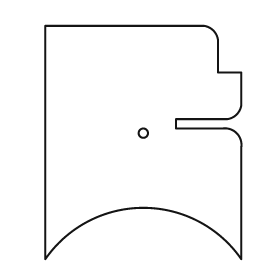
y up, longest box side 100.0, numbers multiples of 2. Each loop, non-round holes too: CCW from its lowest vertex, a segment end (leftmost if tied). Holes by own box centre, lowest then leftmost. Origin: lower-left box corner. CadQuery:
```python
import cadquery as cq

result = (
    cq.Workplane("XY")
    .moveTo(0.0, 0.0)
    .threePointArc((42.0, 22.0), (84.0, 0.0))
    .lineTo(84.0, 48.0)
    .threePointArc((82.0, 54.0), (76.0, 56.0))
    .lineTo(56.0, 56.0)
    .lineTo(56.0, 60.0)
    .lineTo(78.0, 60.0)
    .threePointArc((82.0, 62.0), (84.0, 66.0))
    .lineTo(84.0, 80.0)
    .lineTo(74.0, 80.0)
    .lineTo(74.0, 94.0)
    .threePointArc((72.0, 98.0), (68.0, 100.0))
    .lineTo(0.0, 100.0)
    .close()
    .moveTo(42.0, 54.0)
    .circle(2.0)
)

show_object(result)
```